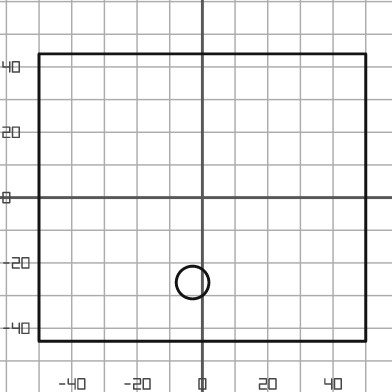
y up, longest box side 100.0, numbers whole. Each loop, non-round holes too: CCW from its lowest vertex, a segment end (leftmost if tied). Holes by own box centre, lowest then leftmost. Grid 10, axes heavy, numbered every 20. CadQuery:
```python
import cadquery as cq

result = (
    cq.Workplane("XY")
    .moveTo(-50.0, -44.0)
    .lineTo(50.0, -44.0)
    .lineTo(50.0, 44.0)
    .lineTo(-50.0, 44.0)
    .close()
    .moveTo(-3.0, -26.0)
    .circle(5.0)
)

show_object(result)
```